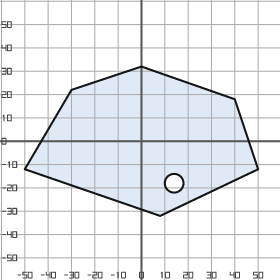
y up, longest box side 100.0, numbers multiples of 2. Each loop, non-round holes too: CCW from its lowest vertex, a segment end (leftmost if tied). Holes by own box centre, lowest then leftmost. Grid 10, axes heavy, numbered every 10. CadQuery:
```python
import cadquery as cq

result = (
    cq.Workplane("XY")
    .moveTo(8.0, -32.0)
    .lineTo(50.0, -12.0)
    .lineTo(40.0, 18.0)
    .lineTo(0.0, 32.0)
    .lineTo(-30.0, 22.0)
    .lineTo(-50.0, -12.0)
    .close()
    .moveTo(14.0, -18.0)
    .circle(4.0)
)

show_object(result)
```